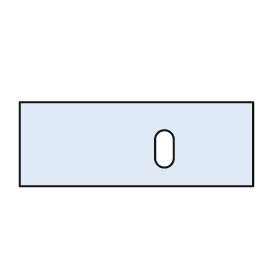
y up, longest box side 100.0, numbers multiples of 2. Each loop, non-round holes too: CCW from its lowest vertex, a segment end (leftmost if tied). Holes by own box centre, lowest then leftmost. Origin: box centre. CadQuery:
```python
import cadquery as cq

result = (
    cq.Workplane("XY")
    .moveTo(-50.0, -18.0)
    .lineTo(50.0, -18.0)
    .lineTo(50.0, 18.0)
    .lineTo(-50.0, 18.0)
    .close()
    .moveTo(8.0, -6.0)
    .threePointArc((12.0, -10.0), (16.0, -6.0))
    .lineTo(16.0, 2.0)
    .threePointArc((12.0, 6.0), (8.0, 2.0))
    .close()
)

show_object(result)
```